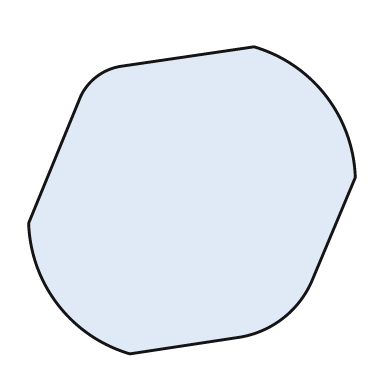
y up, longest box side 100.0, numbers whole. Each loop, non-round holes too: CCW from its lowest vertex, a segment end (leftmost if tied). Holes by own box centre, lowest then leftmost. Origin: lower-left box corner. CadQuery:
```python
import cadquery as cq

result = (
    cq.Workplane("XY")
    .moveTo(31.0, 0.0)
    .lineTo(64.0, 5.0)
    .threePointArc((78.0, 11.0), (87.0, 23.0))
    .lineTo(100.0, 54.0)
    .threePointArc((91.0, 79.0), (69.0, 94.0))
    .lineTo(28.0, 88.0)
    .threePointArc((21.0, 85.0), (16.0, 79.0))
    .lineTo(0.0, 40.0)
    .threePointArc((9.0, 15.0), (31.0, 0.0))
    .close()
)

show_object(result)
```